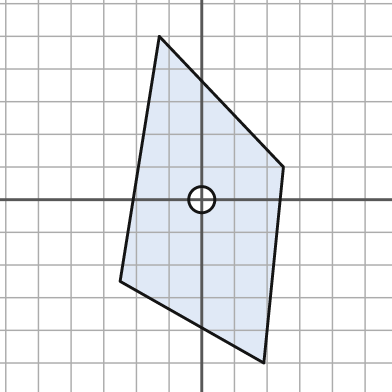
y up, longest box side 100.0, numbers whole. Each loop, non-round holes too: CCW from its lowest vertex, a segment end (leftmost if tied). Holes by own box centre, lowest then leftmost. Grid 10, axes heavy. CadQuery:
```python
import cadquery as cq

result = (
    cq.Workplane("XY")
    .moveTo(19.0, -50.0)
    .lineTo(25.0, 10.0)
    .lineTo(-13.0, 50.0)
    .lineTo(-25.0, -25.0)
    .close()
    .moveTo(0.0, 0.0)
    .circle(4.0)
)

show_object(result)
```